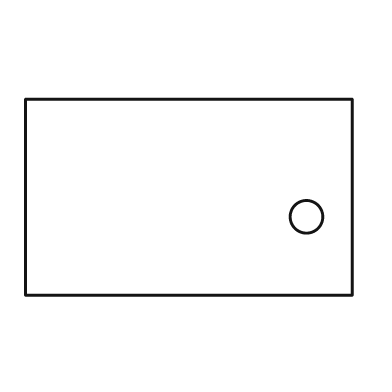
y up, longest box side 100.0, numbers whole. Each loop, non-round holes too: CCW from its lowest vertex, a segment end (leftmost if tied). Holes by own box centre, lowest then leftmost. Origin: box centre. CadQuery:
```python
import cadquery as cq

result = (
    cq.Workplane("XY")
    .moveTo(-50.0, -30.0)
    .lineTo(50.0, -30.0)
    .lineTo(50.0, 30.0)
    .lineTo(-50.0, 30.0)
    .close()
    .moveTo(36.0, -6.0)
    .circle(5.0)
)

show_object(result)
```